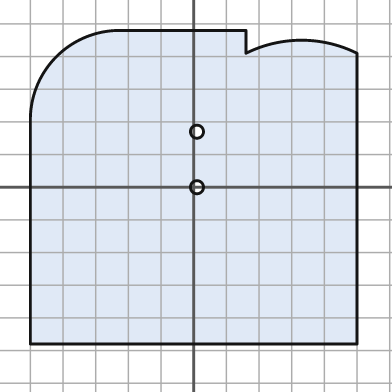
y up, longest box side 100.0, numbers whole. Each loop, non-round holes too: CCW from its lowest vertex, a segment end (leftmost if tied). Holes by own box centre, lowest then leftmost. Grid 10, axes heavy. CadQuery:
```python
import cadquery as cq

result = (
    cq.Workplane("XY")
    .moveTo(-50.0, -48.0)
    .lineTo(50.0, -48.0)
    .lineTo(50.0, 41.0)
    .threePointArc((33.0, 45.0), (16.0, 41.0))
    .lineTo(16.0, 48.0)
    .lineTo(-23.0, 48.0)
    .threePointArc((-42.0, 40.0), (-50.0, 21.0))
    .close()
    .moveTo(1.0, 0.0)
    .circle(2.0)
    .moveTo(1.0, 17.0)
    .circle(2.0)
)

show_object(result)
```